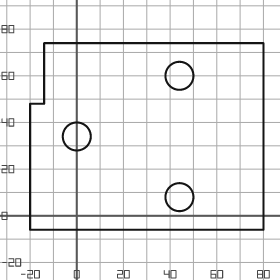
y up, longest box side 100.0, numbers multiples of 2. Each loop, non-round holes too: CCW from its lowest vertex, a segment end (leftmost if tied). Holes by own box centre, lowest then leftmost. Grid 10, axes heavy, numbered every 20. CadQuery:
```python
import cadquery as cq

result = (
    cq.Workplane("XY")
    .moveTo(-20.0, -6.0)
    .lineTo(80.0, -6.0)
    .lineTo(80.0, 74.0)
    .lineTo(-14.0, 74.0)
    .lineTo(-14.0, 48.0)
    .lineTo(-20.0, 48.0)
    .close()
    .moveTo(44.0, 8.0)
    .circle(6.0)
    .moveTo(0.0, 34.0)
    .circle(6.0)
    .moveTo(44.0, 60.0)
    .circle(6.0)
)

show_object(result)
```